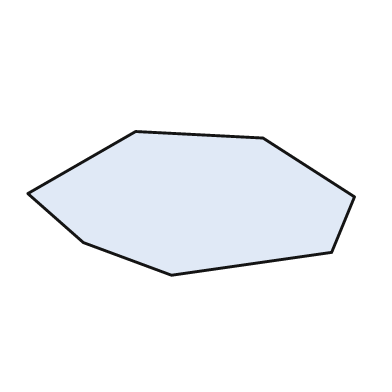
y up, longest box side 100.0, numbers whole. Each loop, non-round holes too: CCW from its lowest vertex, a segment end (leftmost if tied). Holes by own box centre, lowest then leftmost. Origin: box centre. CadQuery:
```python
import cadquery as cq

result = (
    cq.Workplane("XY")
    .moveTo(-6.0, -22.0)
    .lineTo(43.0, -15.0)
    .lineTo(50.0, 2.0)
    .lineTo(22.0, 20.0)
    .lineTo(-17.0, 22.0)
    .lineTo(-50.0, 3.0)
    .lineTo(-33.0, -12.0)
    .close()
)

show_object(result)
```